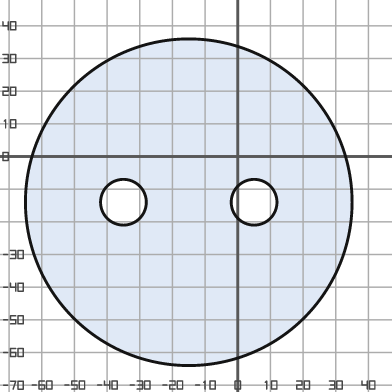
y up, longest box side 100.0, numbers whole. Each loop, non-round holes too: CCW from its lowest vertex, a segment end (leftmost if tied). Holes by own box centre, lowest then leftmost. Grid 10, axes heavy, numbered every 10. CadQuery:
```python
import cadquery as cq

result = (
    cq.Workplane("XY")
    .moveTo(-15.0, -14.0)
    .circle(50.0)
    .moveTo(-35.0, -14.0)
    .circle(7.0)
    .moveTo(5.0, -14.0)
    .circle(7.0)
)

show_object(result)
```